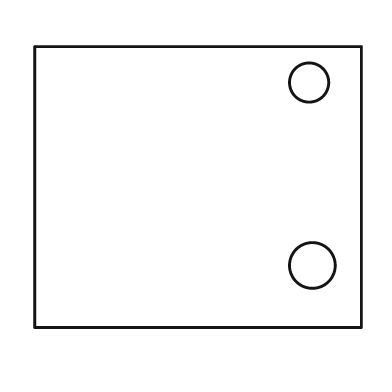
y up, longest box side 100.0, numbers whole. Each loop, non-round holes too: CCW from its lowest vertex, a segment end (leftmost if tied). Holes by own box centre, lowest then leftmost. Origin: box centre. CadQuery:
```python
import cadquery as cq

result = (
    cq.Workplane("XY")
    .moveTo(-50.0, -43.0)
    .lineTo(50.0, -43.0)
    .lineTo(50.0, 43.0)
    .lineTo(-50.0, 43.0)
    .close()
    .moveTo(35.0, -24.0)
    .circle(7.0)
    .moveTo(34.0, 32.0)
    .circle(6.0)
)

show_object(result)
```